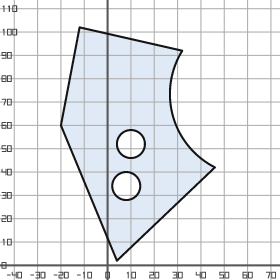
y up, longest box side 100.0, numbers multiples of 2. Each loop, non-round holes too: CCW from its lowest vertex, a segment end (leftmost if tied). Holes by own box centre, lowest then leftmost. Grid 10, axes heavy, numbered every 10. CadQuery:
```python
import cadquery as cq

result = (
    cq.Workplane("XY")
    .moveTo(4.0, 2.0)
    .lineTo(46.0, 42.0)
    .threePointArc((28.0, 64.0), (32.0, 92.0))
    .lineTo(-12.0, 102.0)
    .lineTo(-20.0, 60.0)
    .close()
    .moveTo(8.0, 34.0)
    .circle(6.0)
    .moveTo(10.0, 52.0)
    .circle(6.0)
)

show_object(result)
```